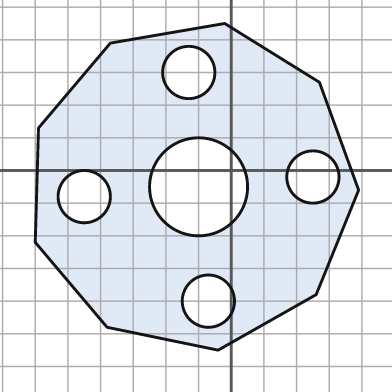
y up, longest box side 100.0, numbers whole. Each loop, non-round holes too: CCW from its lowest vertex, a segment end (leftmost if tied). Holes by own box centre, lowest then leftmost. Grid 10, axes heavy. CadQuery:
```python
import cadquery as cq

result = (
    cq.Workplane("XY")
    .moveTo(-4.0, -55.0)
    .lineTo(26.0, -38.0)
    .lineTo(39.0, -6.0)
    .lineTo(27.0, 27.0)
    .lineTo(-2.0, 45.0)
    .lineTo(-37.0, 39.0)
    .lineTo(-59.0, 13.0)
    .lineTo(-60.0, -22.0)
    .lineTo(-38.0, -48.0)
    .close()
    .moveTo(-7.0, -40.0)
    .circle(8.0)
    .moveTo(-45.0, -8.0)
    .circle(8.0)
    .moveTo(-10.0, -5.0)
    .circle(15.0)
    .moveTo(25.0, -2.0)
    .circle(8.0)
    .moveTo(-13.0, 30.0)
    .circle(8.0)
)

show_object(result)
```